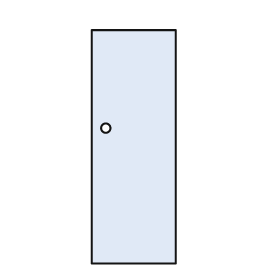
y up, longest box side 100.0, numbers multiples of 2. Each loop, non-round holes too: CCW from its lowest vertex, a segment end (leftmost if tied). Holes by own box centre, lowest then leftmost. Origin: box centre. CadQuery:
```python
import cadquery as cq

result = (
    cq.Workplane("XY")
    .moveTo(-18.0, -50.0)
    .lineTo(18.0, -50.0)
    .lineTo(18.0, 50.0)
    .lineTo(-18.0, 50.0)
    .close()
    .moveTo(-12.0, 8.0)
    .circle(2.0)
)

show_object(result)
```